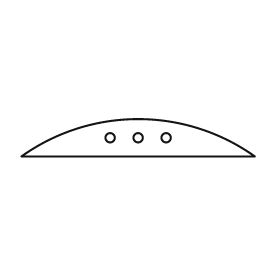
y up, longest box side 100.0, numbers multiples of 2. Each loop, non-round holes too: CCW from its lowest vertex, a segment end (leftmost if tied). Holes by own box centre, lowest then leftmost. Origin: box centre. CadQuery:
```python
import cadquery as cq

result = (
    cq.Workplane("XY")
    .moveTo(-50.0, -8.0)
    .lineTo(50.0, -8.0)
    .threePointArc((0.0, 8.0), (-50.0, -8.0))
    .close()
    .moveTo(-12.0, 0.0)
    .circle(2.0)
    .moveTo(0.0, 0.0)
    .circle(2.0)
    .moveTo(12.0, 0.0)
    .circle(2.0)
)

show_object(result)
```